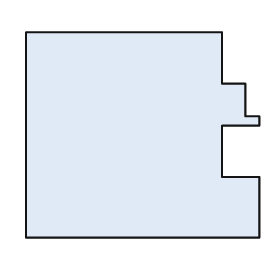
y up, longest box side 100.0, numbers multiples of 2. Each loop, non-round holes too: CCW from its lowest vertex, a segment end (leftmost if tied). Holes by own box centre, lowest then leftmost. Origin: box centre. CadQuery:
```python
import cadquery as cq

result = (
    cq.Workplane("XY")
    .moveTo(-50.0, -44.0)
    .lineTo(50.0, -44.0)
    .lineTo(50.0, -18.0)
    .lineTo(34.0, -18.0)
    .lineTo(34.0, 4.0)
    .lineTo(50.0, 4.0)
    .lineTo(50.0, 8.0)
    .lineTo(44.0, 8.0)
    .lineTo(44.0, 22.0)
    .lineTo(34.0, 22.0)
    .lineTo(34.0, 44.0)
    .lineTo(-50.0, 44.0)
    .close()
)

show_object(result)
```